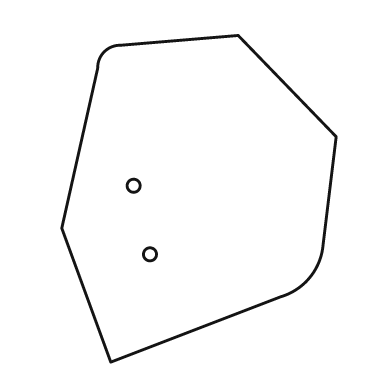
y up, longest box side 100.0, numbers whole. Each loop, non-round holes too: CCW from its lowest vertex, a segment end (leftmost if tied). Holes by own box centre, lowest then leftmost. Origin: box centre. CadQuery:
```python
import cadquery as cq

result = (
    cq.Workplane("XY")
    .moveTo(-27.0, -50.0)
    .lineTo(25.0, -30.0)
    .threePointArc((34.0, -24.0), (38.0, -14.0))
    .lineTo(42.0, 19.0)
    .lineTo(12.0, 50.0)
    .lineTo(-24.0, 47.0)
    .threePointArc((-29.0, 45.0), (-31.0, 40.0))
    .lineTo(-42.0, -9.0)
    .close()
    .moveTo(-15.0, -17.0)
    .circle(2.0)
    .moveTo(-20.0, 4.0)
    .circle(2.0)
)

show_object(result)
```